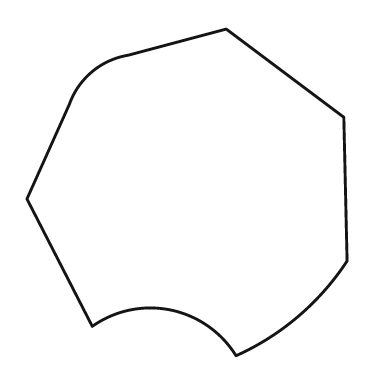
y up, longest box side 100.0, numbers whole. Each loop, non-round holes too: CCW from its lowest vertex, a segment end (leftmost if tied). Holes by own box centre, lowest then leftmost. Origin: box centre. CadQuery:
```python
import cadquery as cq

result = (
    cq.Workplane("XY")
    .moveTo(15.0, -50.0)
    .threePointArc((34.0, -38.0), (49.0, -21.0))
    .lineTo(48.0, 23.0)
    .lineTo(12.0, 50.0)
    .lineTo(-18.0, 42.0)
    .threePointArc((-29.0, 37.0), (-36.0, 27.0))
    .lineTo(-49.0, -2.0)
    .lineTo(-29.0, -41.0)
    .threePointArc((-5.0, -36.0), (15.0, -50.0))
    .close()
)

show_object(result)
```